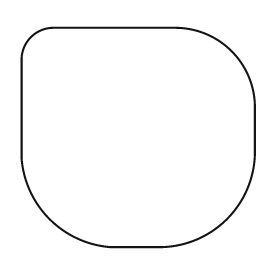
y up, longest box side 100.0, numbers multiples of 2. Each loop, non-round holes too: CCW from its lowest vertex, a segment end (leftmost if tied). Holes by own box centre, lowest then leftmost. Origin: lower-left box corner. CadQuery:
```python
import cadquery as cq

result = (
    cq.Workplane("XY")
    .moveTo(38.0, 0.0)
    .lineTo(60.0, 0.0)
    .threePointArc((88.0, 12.0), (100.0, 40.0))
    .lineTo(100.0, 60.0)
    .threePointArc((90.0, 84.0), (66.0, 94.0))
    .lineTo(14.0, 94.0)
    .threePointArc((4.0, 90.0), (0.0, 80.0))
    .lineTo(0.0, 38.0)
    .threePointArc((12.0, 12.0), (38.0, 0.0))
    .close()
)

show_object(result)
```